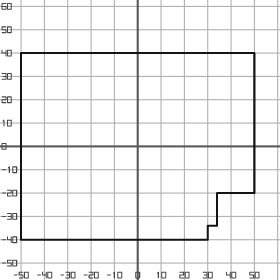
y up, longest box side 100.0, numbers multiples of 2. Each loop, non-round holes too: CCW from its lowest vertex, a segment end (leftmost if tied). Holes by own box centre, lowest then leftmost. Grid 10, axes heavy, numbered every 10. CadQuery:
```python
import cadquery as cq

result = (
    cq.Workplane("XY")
    .moveTo(-50.0, -40.0)
    .lineTo(30.0, -40.0)
    .lineTo(30.0, -34.0)
    .lineTo(34.0, -34.0)
    .lineTo(34.0, -20.0)
    .lineTo(50.0, -20.0)
    .lineTo(50.0, 40.0)
    .lineTo(-50.0, 40.0)
    .close()
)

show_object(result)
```